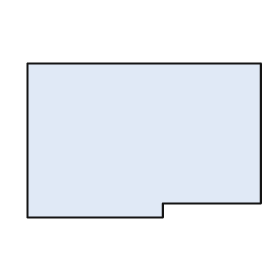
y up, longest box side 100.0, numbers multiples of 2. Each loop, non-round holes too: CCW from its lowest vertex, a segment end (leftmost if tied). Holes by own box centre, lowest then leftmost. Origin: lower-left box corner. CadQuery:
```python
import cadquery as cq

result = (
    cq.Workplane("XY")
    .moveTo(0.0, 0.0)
    .lineTo(58.0, 0.0)
    .lineTo(58.0, 6.0)
    .lineTo(100.0, 6.0)
    .lineTo(100.0, 66.0)
    .lineTo(0.0, 66.0)
    .close()
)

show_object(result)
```